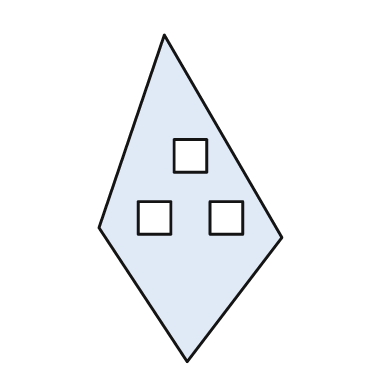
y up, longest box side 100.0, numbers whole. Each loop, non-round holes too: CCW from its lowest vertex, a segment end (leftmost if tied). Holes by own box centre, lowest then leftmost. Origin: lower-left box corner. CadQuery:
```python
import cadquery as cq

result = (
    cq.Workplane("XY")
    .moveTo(27.0, 0.0)
    .lineTo(56.0, 38.0)
    .lineTo(20.0, 100.0)
    .lineTo(0.0, 41.0)
    .close()
    .moveTo(12.0, 39.0)
    .lineTo(22.0, 39.0)
    .lineTo(22.0, 49.0)
    .lineTo(12.0, 49.0)
    .close()
    .moveTo(34.0, 39.0)
    .lineTo(44.0, 39.0)
    .lineTo(44.0, 49.0)
    .lineTo(34.0, 49.0)
    .close()
    .moveTo(23.0, 58.0)
    .lineTo(33.0, 58.0)
    .lineTo(33.0, 68.0)
    .lineTo(23.0, 68.0)
    .close()
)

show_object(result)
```